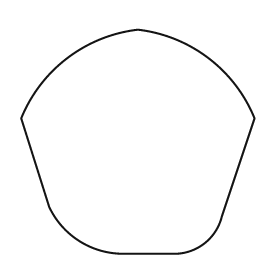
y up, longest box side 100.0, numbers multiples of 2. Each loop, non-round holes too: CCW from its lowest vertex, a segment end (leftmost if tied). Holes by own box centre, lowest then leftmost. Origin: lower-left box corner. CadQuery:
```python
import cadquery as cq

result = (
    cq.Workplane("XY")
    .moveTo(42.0, 0.0)
    .lineTo(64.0, 0.0)
    .threePointArc((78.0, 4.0), (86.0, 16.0))
    .lineTo(100.0, 58.0)
    .threePointArc((80.0, 84.0), (50.0, 96.0))
    .threePointArc((20.0, 84.0), (0.0, 58.0))
    .lineTo(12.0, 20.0)
    .threePointArc((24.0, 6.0), (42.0, 0.0))
    .close()
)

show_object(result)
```